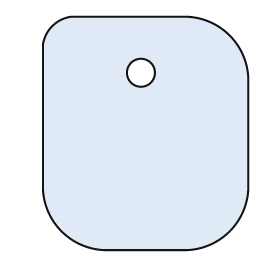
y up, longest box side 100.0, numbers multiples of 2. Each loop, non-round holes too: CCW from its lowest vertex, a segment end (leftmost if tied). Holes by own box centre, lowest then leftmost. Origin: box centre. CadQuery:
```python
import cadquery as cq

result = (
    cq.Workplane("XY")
    .moveTo(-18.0, -50.0)
    .lineTo(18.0, -50.0)
    .threePointArc((36.0, -42.0), (44.0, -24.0))
    .lineTo(44.0, 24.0)
    .threePointArc((36.0, 42.0), (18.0, 50.0))
    .lineTo(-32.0, 50.0)
    .threePointArc((-40.0, 46.0), (-44.0, 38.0))
    .lineTo(-44.0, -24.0)
    .threePointArc((-36.0, -42.0), (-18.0, -50.0))
    .close()
    .moveTo(-2.0, 26.0)
    .circle(6.0)
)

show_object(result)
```